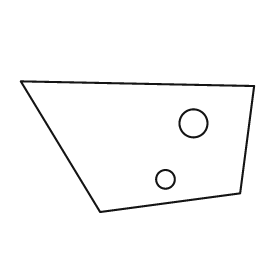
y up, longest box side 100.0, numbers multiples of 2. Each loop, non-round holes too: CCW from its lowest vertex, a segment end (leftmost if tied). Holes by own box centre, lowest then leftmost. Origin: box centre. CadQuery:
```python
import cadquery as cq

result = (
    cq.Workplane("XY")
    .moveTo(-16.0, -28.0)
    .lineTo(44.0, -20.0)
    .lineTo(50.0, 26.0)
    .lineTo(-50.0, 28.0)
    .close()
    .moveTo(12.0, -14.0)
    .circle(4.0)
    .moveTo(24.0, 10.0)
    .circle(6.0)
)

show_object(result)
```